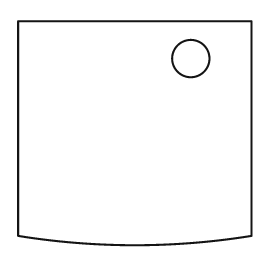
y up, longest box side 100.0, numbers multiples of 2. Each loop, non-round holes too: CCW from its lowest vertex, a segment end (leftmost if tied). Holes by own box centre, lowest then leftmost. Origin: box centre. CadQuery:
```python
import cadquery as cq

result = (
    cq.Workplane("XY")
    .moveTo(-50.0, -44.0)
    .threePointArc((0.0, -48.0), (50.0, -44.0))
    .lineTo(50.0, 48.0)
    .lineTo(-50.0, 48.0)
    .close()
    .moveTo(24.0, 32.0)
    .circle(8.0)
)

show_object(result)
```